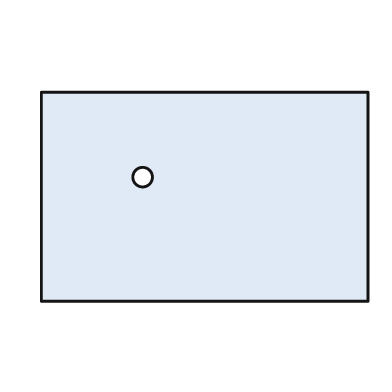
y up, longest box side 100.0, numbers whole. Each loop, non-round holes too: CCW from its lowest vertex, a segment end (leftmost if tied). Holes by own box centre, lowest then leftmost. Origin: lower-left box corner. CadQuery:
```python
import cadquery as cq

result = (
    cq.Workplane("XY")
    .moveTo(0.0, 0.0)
    .lineTo(100.0, 0.0)
    .lineTo(100.0, 64.0)
    .lineTo(0.0, 64.0)
    .close()
    .moveTo(31.0, 38.0)
    .circle(3.0)
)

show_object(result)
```